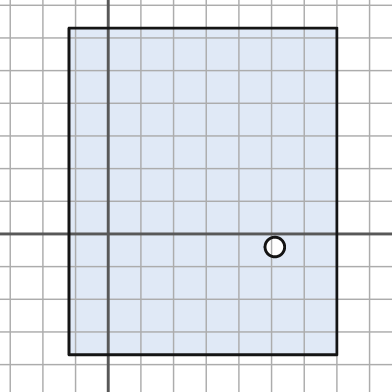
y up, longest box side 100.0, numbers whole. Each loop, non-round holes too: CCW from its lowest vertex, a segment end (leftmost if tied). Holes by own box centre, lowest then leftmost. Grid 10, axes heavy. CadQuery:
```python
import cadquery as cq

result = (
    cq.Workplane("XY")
    .moveTo(-12.0, -37.0)
    .lineTo(70.0, -37.0)
    .lineTo(70.0, 63.0)
    .lineTo(-12.0, 63.0)
    .close()
    .moveTo(51.0, -4.0)
    .circle(3.0)
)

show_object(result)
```